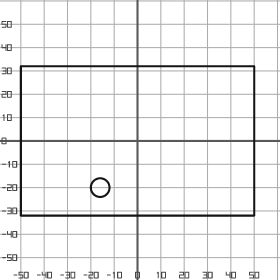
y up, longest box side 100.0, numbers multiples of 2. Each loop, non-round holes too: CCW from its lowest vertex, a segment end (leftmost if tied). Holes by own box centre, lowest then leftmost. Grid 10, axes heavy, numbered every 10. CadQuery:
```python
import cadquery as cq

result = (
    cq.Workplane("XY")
    .moveTo(-50.0, -32.0)
    .lineTo(50.0, -32.0)
    .lineTo(50.0, 32.0)
    .lineTo(-50.0, 32.0)
    .close()
    .moveTo(-16.0, -20.0)
    .circle(4.0)
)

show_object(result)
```